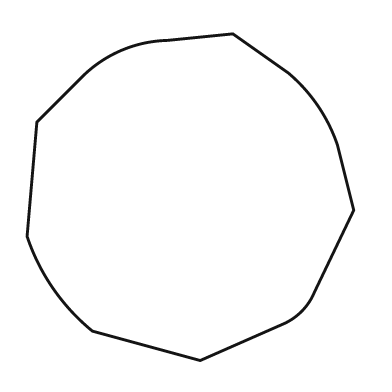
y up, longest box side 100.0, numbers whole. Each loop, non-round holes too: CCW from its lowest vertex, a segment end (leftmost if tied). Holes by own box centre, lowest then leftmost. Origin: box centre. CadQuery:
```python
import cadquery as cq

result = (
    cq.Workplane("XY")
    .moveTo(3.0, -50.0)
    .lineTo(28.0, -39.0)
    .threePointArc((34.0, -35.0), (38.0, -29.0))
    .lineTo(50.0, -4.0)
    .lineTo(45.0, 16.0)
    .threePointArc((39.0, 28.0), (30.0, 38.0))
    .lineTo(13.0, 50.0)
    .lineTo(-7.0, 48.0)
    .threePointArc((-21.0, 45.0), (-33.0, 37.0))
    .lineTo(-47.0, 23.0)
    .lineTo(-50.0, -12.0)
    .threePointArc((-42.0, -28.0), (-30.0, -41.0))
    .close()
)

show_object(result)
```